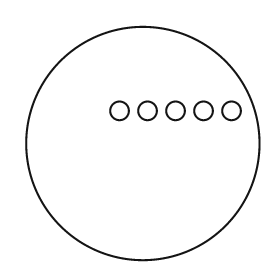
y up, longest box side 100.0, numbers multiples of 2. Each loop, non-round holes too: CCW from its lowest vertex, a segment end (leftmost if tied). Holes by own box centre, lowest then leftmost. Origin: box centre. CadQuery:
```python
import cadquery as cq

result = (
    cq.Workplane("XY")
    .moveTo(0.0, 0.0)
    .circle(50.0)
    .moveTo(-10.0, 14.0)
    .circle(4.0)
    .moveTo(2.0, 14.0)
    .circle(4.0)
    .moveTo(14.0, 14.0)
    .circle(4.0)
    .moveTo(26.0, 14.0)
    .circle(4.0)
    .moveTo(38.0, 14.0)
    .circle(4.0)
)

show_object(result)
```